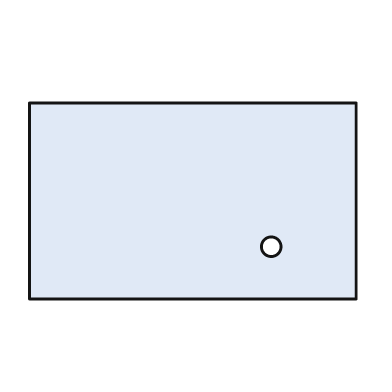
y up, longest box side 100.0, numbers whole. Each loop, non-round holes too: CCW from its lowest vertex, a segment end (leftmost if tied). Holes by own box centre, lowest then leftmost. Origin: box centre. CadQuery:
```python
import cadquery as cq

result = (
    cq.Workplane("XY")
    .moveTo(-50.0, -30.0)
    .lineTo(50.0, -30.0)
    .lineTo(50.0, 30.0)
    .lineTo(-50.0, 30.0)
    .close()
    .moveTo(24.0, -14.0)
    .circle(3.0)
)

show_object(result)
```